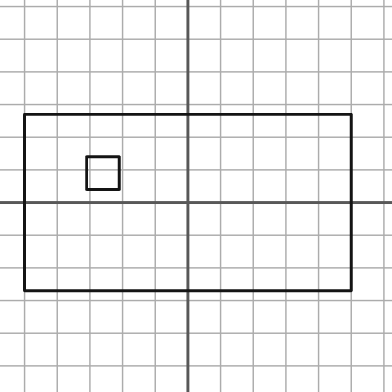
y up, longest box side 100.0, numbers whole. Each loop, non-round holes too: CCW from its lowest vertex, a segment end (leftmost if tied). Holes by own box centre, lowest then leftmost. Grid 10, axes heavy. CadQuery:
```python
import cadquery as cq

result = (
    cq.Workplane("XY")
    .moveTo(-50.0, -27.0)
    .lineTo(50.0, -27.0)
    .lineTo(50.0, 27.0)
    .lineTo(-50.0, 27.0)
    .close()
    .moveTo(-31.0, 4.0)
    .lineTo(-21.0, 4.0)
    .lineTo(-21.0, 14.0)
    .lineTo(-31.0, 14.0)
    .close()
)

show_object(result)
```